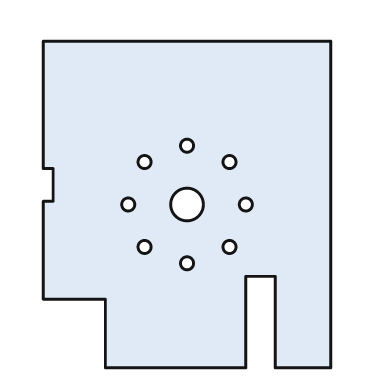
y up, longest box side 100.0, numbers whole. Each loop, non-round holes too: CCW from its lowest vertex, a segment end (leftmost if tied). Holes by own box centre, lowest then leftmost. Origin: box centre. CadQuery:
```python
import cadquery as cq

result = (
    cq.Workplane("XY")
    .moveTo(-25.0, -50.0)
    .lineTo(18.0, -50.0)
    .lineTo(18.0, -22.0)
    .lineTo(27.0, -22.0)
    .lineTo(27.0, -50.0)
    .lineTo(44.0, -50.0)
    .lineTo(44.0, 50.0)
    .lineTo(-44.0, 50.0)
    .lineTo(-44.0, 11.0)
    .lineTo(-41.0, 11.0)
    .lineTo(-41.0, 1.0)
    .lineTo(-44.0, 1.0)
    .lineTo(-44.0, -29.0)
    .lineTo(-25.0, -29.0)
    .close()
    .moveTo(0.0, -18.0)
    .circle(2.0)
    .moveTo(-13.0, -13.0)
    .circle(2.0)
    .moveTo(13.0, -13.0)
    .circle(2.0)
    .moveTo(-18.0, 0.0)
    .circle(2.0)
    .moveTo(0.0, 0.0)
    .circle(5.0)
    .moveTo(18.0, 0.0)
    .circle(2.0)
    .moveTo(-13.0, 13.0)
    .circle(2.0)
    .moveTo(13.0, 13.0)
    .circle(2.0)
    .moveTo(0.0, 18.0)
    .circle(2.0)
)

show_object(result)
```